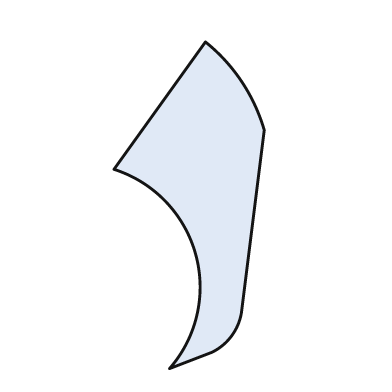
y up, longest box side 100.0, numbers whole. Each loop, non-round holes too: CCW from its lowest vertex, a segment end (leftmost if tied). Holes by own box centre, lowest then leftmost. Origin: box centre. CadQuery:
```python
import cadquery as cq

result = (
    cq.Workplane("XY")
    .moveTo(-6.0, -50.0)
    .lineTo(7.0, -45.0)
    .threePointArc((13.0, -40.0), (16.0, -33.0))
    .lineTo(23.0, 23.0)
    .threePointArc((16.0, 38.0), (5.0, 50.0))
    .lineTo(-23.0, 11.0)
    .threePointArc((2.0, -15.0), (-6.0, -50.0))
    .close()
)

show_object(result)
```